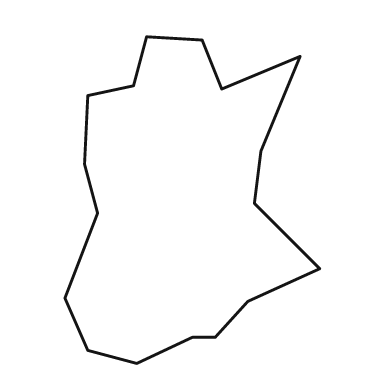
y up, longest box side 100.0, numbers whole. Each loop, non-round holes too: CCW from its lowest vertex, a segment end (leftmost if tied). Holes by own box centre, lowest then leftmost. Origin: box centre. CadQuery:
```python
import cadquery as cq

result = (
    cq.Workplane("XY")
    .moveTo(-17.0, -50.0)
    .lineTo(0.0, -42.0)
    .lineTo(7.0, -42.0)
    .lineTo(17.0, -31.0)
    .lineTo(39.0, -21.0)
    .lineTo(19.0, -1.0)
    .lineTo(21.0, 15.0)
    .lineTo(33.0, 44.0)
    .lineTo(9.0, 34.0)
    .lineTo(3.0, 49.0)
    .lineTo(-14.0, 50.0)
    .lineTo(-18.0, 35.0)
    .lineTo(-32.0, 32.0)
    .lineTo(-33.0, 11.0)
    .lineTo(-29.0, -4.0)
    .lineTo(-39.0, -30.0)
    .lineTo(-32.0, -46.0)
    .close()
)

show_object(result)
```